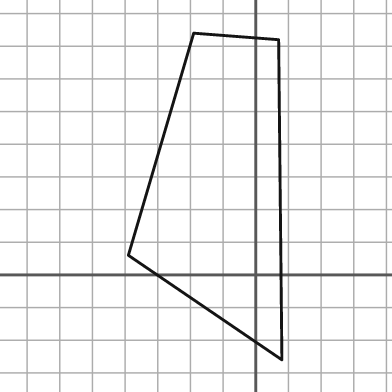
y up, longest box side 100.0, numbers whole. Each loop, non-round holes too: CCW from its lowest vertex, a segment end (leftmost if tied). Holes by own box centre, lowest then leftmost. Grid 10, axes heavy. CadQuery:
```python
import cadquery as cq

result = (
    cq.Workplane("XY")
    .moveTo(8.0, -26.0)
    .lineTo(7.0, 72.0)
    .lineTo(-19.0, 74.0)
    .lineTo(-39.0, 6.0)
    .close()
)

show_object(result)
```